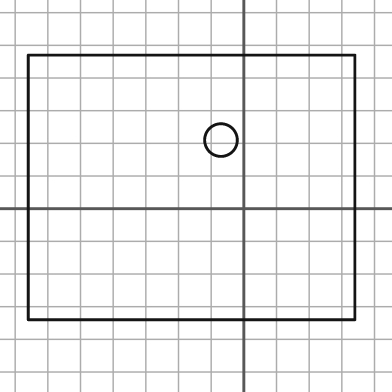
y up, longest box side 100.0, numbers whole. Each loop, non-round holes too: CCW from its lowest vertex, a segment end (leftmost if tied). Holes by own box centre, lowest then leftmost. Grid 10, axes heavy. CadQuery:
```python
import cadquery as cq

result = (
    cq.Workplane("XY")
    .moveTo(-66.0, -34.0)
    .lineTo(34.0, -34.0)
    .lineTo(34.0, 47.0)
    .lineTo(-66.0, 47.0)
    .close()
    .moveTo(-7.0, 21.0)
    .circle(5.0)
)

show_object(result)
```